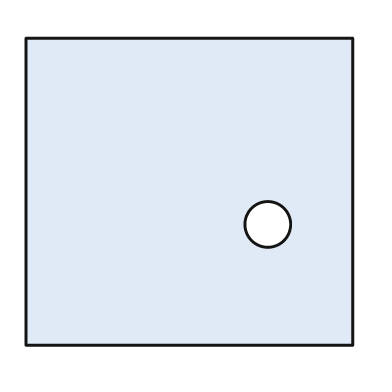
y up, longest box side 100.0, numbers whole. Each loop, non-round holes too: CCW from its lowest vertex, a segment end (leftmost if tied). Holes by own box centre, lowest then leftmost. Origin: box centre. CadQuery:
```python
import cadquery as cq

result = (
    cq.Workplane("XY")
    .moveTo(-50.0, -47.0)
    .lineTo(50.0, -47.0)
    .lineTo(50.0, 47.0)
    .lineTo(-50.0, 47.0)
    .close()
    .moveTo(24.0, -10.0)
    .circle(7.0)
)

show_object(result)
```